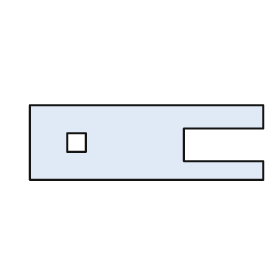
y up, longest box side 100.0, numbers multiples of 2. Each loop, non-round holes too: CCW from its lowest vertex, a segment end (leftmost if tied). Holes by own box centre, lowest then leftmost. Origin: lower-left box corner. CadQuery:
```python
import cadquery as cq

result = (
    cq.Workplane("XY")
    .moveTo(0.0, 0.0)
    .lineTo(100.0, 0.0)
    .lineTo(100.0, 8.0)
    .lineTo(66.0, 8.0)
    .lineTo(66.0, 22.0)
    .lineTo(100.0, 22.0)
    .lineTo(100.0, 32.0)
    .lineTo(0.0, 32.0)
    .close()
    .moveTo(16.0, 12.0)
    .lineTo(24.0, 12.0)
    .lineTo(24.0, 20.0)
    .lineTo(16.0, 20.0)
    .close()
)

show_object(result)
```